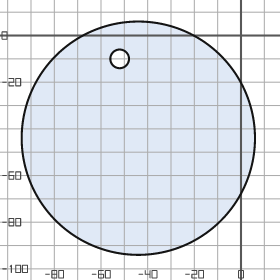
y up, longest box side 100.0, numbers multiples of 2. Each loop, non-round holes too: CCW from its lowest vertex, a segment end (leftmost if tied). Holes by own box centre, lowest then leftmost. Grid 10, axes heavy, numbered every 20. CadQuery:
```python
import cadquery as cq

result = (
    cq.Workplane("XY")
    .moveTo(-44.0, -44.0)
    .circle(50.0)
    .moveTo(-52.0, -10.0)
    .circle(4.0)
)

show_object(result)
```